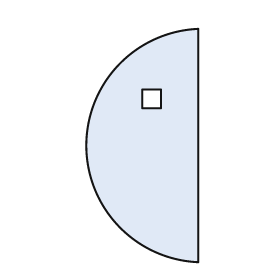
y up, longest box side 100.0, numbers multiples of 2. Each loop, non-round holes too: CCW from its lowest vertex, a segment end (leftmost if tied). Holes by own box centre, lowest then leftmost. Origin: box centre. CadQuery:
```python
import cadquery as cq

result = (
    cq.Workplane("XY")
    .moveTo(24.0, -50.0)
    .lineTo(24.0, 50.0)
    .threePointArc((-24.0, 0.0), (24.0, -50.0))
    .close()
    .moveTo(0.0, 16.0)
    .lineTo(8.0, 16.0)
    .lineTo(8.0, 24.0)
    .lineTo(0.0, 24.0)
    .close()
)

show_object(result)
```